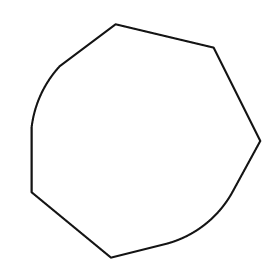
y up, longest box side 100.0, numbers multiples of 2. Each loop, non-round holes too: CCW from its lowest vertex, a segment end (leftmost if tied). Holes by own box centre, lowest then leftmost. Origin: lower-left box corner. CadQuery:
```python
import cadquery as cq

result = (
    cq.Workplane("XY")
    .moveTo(34.0, 0.0)
    .lineTo(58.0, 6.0)
    .threePointArc((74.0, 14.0), (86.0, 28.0))
    .lineTo(98.0, 50.0)
    .lineTo(78.0, 90.0)
    .lineTo(36.0, 100.0)
    .lineTo(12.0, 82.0)
    .threePointArc((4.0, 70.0), (0.0, 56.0))
    .lineTo(0.0, 28.0)
    .close()
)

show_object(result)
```